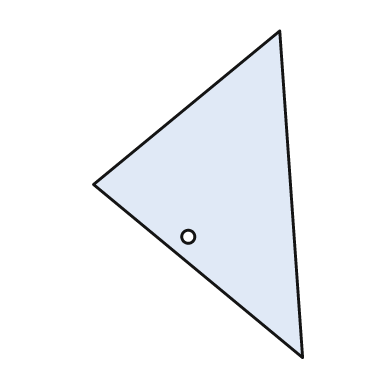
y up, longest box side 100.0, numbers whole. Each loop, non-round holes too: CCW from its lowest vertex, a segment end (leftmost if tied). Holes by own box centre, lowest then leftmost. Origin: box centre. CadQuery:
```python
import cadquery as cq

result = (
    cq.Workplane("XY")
    .moveTo(32.0, -50.0)
    .lineTo(25.0, 50.0)
    .lineTo(-32.0, 3.0)
    .close()
    .moveTo(-3.0, -13.0)
    .circle(2.0)
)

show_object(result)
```